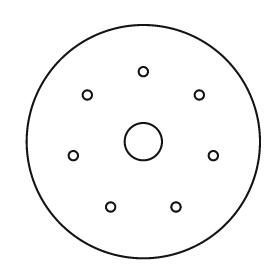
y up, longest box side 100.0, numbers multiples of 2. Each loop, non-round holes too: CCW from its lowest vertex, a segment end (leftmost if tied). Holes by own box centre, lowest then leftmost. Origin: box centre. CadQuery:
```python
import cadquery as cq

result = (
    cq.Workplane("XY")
    .moveTo(0.0, 0.0)
    .circle(50.0)
    .moveTo(-14.0, -28.0)
    .circle(2.0)
    .moveTo(14.0, -28.0)
    .circle(2.0)
    .moveTo(-30.0, -6.0)
    .circle(2.0)
    .moveTo(30.0, -6.0)
    .circle(2.0)
    .moveTo(0.0, 0.0)
    .circle(8.0)
    .moveTo(-24.0, 20.0)
    .circle(2.0)
    .moveTo(24.0, 20.0)
    .circle(2.0)
    .moveTo(0.0, 30.0)
    .circle(2.0)
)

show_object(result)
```